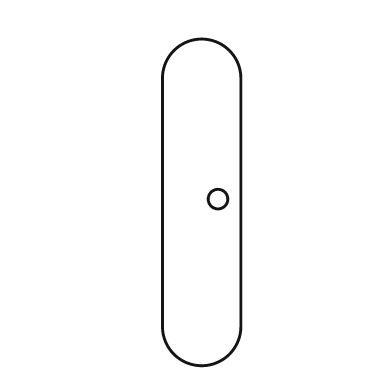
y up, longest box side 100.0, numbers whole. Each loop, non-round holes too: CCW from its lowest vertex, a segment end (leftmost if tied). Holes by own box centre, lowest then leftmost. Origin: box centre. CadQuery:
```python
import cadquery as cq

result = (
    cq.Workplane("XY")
    .moveTo(-12.0, -38.0)
    .threePointArc((0.0, -50.0), (12.0, -38.0))
    .lineTo(12.0, 38.0)
    .threePointArc((0.0, 50.0), (-12.0, 38.0))
    .close()
    .moveTo(5.0, 1.0)
    .circle(3.0)
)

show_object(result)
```